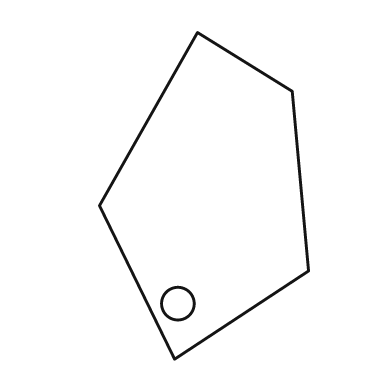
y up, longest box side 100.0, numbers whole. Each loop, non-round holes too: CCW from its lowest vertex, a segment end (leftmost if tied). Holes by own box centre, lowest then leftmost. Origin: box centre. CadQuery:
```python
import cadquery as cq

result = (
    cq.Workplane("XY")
    .moveTo(-9.0, -50.0)
    .lineTo(32.0, -23.0)
    .lineTo(27.0, 32.0)
    .lineTo(-2.0, 50.0)
    .lineTo(-32.0, -3.0)
    .close()
    .moveTo(-8.0, -33.0)
    .circle(5.0)
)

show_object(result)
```